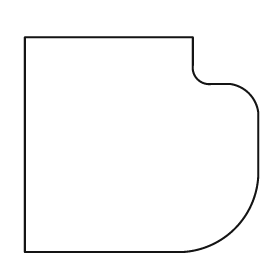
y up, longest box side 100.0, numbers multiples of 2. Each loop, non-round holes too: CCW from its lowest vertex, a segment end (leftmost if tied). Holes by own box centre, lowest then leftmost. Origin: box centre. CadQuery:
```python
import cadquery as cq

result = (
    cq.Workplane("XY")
    .moveTo(-50.0, -46.0)
    .lineTo(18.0, -46.0)
    .threePointArc((40.0, -36.0), (50.0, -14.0))
    .lineTo(50.0, 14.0)
    .threePointArc((46.0, 22.0), (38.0, 26.0))
    .lineTo(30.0, 26.0)
    .threePointArc((24.0, 28.0), (22.0, 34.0))
    .lineTo(22.0, 46.0)
    .lineTo(-50.0, 46.0)
    .close()
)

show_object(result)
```